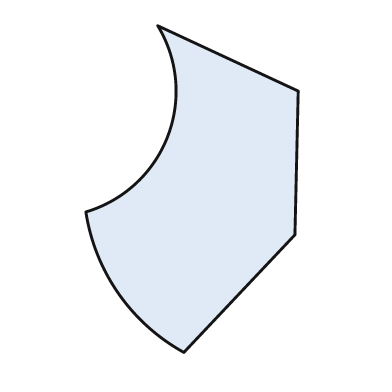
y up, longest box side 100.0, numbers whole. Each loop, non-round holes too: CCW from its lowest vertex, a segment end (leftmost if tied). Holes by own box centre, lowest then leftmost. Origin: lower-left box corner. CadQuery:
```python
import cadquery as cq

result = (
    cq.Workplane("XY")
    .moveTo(30.0, 0.0)
    .lineTo(64.0, 36.0)
    .lineTo(65.0, 80.0)
    .lineTo(22.0, 100.0)
    .threePointArc((25.0, 66.0), (0.0, 43.0))
    .threePointArc((10.0, 18.0), (30.0, 0.0))
    .close()
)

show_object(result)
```